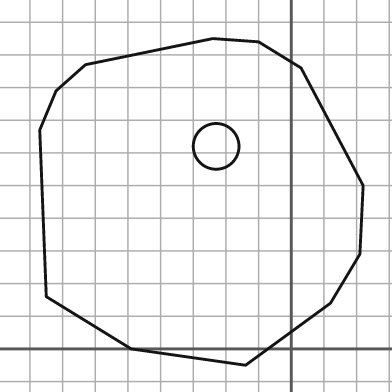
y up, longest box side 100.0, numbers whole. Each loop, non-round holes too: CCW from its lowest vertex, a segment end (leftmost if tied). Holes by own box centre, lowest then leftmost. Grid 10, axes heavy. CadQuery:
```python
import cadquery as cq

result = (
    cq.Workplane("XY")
    .moveTo(-14.0, -5.0)
    .lineTo(12.0, 14.0)
    .lineTo(21.0, 29.0)
    .lineTo(22.0, 50.0)
    .lineTo(3.0, 86.0)
    .lineTo(-10.0, 94.0)
    .lineTo(-24.0, 95.0)
    .lineTo(-63.0, 87.0)
    .lineTo(-72.0, 79.0)
    .lineTo(-77.0, 67.0)
    .lineTo(-75.0, 16.0)
    .lineTo(-49.0, 0.0)
    .close()
    .moveTo(-23.0, 62.0)
    .circle(7.0)
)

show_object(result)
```